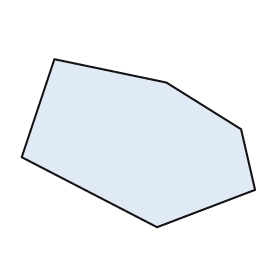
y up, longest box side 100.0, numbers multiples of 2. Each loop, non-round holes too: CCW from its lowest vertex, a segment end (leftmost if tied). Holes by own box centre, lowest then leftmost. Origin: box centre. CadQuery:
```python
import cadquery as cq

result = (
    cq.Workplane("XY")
    .moveTo(8.0, -36.0)
    .lineTo(50.0, -20.0)
    .lineTo(44.0, 6.0)
    .lineTo(12.0, 26.0)
    .lineTo(-36.0, 36.0)
    .lineTo(-50.0, -6.0)
    .close()
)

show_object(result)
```